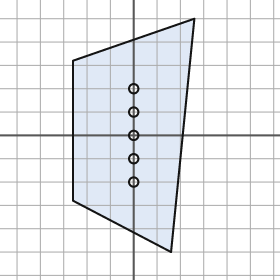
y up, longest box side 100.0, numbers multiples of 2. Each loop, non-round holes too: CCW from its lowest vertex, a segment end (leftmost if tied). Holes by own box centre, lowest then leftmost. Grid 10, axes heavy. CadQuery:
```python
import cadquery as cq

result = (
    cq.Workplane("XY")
    .moveTo(16.0, -50.0)
    .lineTo(26.0, 50.0)
    .lineTo(-26.0, 32.0)
    .lineTo(-26.0, -28.0)
    .close()
    .moveTo(0.0, -20.0)
    .circle(2.0)
    .moveTo(0.0, -10.0)
    .circle(2.0)
    .moveTo(0.0, 0.0)
    .circle(2.0)
    .moveTo(0.0, 10.0)
    .circle(2.0)
    .moveTo(0.0, 20.0)
    .circle(2.0)
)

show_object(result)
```